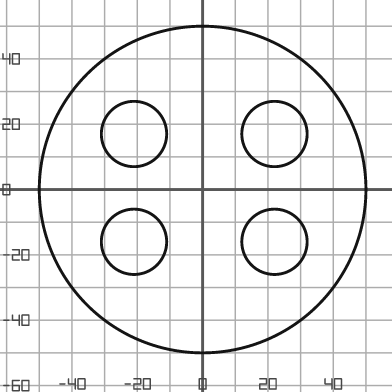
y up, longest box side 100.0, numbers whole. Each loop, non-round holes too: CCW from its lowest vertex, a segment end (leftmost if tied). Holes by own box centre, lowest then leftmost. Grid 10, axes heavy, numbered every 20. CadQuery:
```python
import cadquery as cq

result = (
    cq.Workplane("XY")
    .moveTo(0.0, 0.0)
    .circle(50.0)
    .moveTo(-21.0, -16.0)
    .circle(10.0)
    .moveTo(22.0, -16.0)
    .circle(10.0)
    .moveTo(-21.0, 17.0)
    .circle(10.0)
    .moveTo(22.0, 17.0)
    .circle(10.0)
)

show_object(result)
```